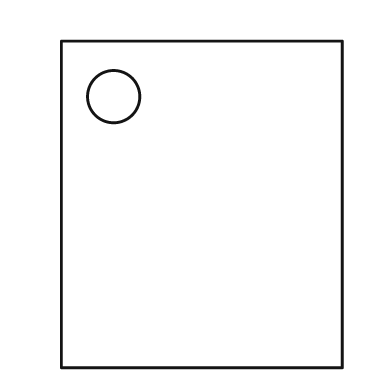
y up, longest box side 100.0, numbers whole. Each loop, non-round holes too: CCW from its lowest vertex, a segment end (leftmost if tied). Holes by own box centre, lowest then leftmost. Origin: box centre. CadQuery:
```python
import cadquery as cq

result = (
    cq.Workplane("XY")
    .moveTo(-43.0, -50.0)
    .lineTo(43.0, -50.0)
    .lineTo(43.0, 50.0)
    .lineTo(-43.0, 50.0)
    .close()
    .moveTo(-27.0, 33.0)
    .circle(8.0)
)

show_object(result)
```